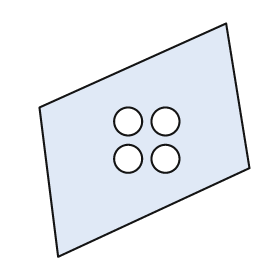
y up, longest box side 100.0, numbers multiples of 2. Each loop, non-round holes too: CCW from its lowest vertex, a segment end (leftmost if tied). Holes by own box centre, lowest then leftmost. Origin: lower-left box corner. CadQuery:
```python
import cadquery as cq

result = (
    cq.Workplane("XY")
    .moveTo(8.0, 0.0)
    .lineTo(90.0, 38.0)
    .lineTo(80.0, 100.0)
    .lineTo(0.0, 64.0)
    .close()
    .moveTo(38.0, 42.0)
    .circle(6.0)
    .moveTo(54.0, 42.0)
    .circle(6.0)
    .moveTo(38.0, 58.0)
    .circle(6.0)
    .moveTo(54.0, 58.0)
    .circle(6.0)
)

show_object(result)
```